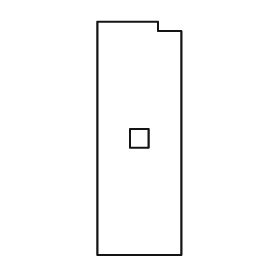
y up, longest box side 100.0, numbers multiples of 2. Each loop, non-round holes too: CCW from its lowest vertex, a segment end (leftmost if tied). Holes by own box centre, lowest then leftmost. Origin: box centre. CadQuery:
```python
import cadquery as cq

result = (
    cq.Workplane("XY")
    .moveTo(-18.0, -50.0)
    .lineTo(18.0, -50.0)
    .lineTo(18.0, 46.0)
    .lineTo(8.0, 46.0)
    .lineTo(8.0, 50.0)
    .lineTo(-18.0, 50.0)
    .close()
    .moveTo(-4.0, -4.0)
    .lineTo(4.0, -4.0)
    .lineTo(4.0, 4.0)
    .lineTo(-4.0, 4.0)
    .close()
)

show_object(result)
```